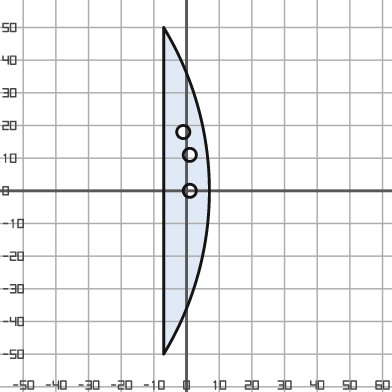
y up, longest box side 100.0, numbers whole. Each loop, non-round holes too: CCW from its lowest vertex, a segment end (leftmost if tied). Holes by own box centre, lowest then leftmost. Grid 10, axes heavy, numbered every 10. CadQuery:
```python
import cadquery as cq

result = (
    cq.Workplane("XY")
    .moveTo(-7.0, -50.0)
    .threePointArc((7.0, 0.0), (-7.0, 50.0))
    .close()
    .moveTo(1.0, 0.0)
    .circle(2.0)
    .moveTo(1.0, 11.0)
    .circle(2.0)
    .moveTo(-1.0, 18.0)
    .circle(2.0)
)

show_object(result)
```